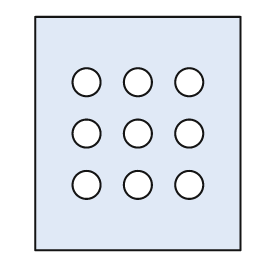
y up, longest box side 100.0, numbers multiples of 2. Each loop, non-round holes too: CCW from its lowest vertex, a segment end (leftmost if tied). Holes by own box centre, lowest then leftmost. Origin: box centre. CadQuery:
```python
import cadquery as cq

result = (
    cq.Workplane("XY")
    .moveTo(-44.0, -50.0)
    .lineTo(44.0, -50.0)
    .lineTo(44.0, 50.0)
    .lineTo(-44.0, 50.0)
    .close()
    .moveTo(-22.0, -22.0)
    .circle(6.0)
    .moveTo(0.0, -22.0)
    .circle(6.0)
    .moveTo(22.0, -22.0)
    .circle(6.0)
    .moveTo(-22.0, 0.0)
    .circle(6.0)
    .moveTo(0.0, 0.0)
    .circle(6.0)
    .moveTo(22.0, 0.0)
    .circle(6.0)
    .moveTo(-22.0, 22.0)
    .circle(6.0)
    .moveTo(0.0, 22.0)
    .circle(6.0)
    .moveTo(22.0, 22.0)
    .circle(6.0)
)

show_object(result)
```